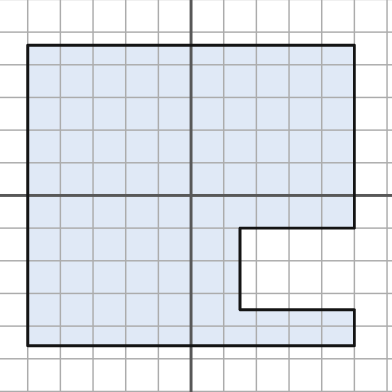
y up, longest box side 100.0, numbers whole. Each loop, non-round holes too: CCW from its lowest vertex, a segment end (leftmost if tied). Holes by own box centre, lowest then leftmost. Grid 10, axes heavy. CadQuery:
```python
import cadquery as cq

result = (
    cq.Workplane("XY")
    .moveTo(-50.0, -46.0)
    .lineTo(50.0, -46.0)
    .lineTo(50.0, -35.0)
    .lineTo(15.0, -35.0)
    .lineTo(15.0, -10.0)
    .lineTo(50.0, -10.0)
    .lineTo(50.0, 46.0)
    .lineTo(-50.0, 46.0)
    .close()
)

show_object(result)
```